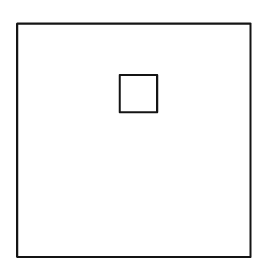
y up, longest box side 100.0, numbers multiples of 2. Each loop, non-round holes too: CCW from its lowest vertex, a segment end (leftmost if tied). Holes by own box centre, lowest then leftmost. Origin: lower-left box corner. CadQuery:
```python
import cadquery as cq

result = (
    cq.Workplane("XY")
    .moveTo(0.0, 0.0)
    .lineTo(100.0, 0.0)
    .lineTo(100.0, 100.0)
    .lineTo(0.0, 100.0)
    .close()
    .moveTo(44.0, 62.0)
    .lineTo(60.0, 62.0)
    .lineTo(60.0, 78.0)
    .lineTo(44.0, 78.0)
    .close()
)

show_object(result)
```